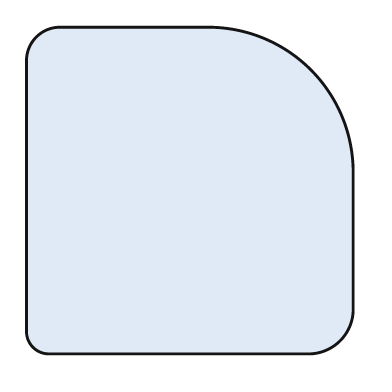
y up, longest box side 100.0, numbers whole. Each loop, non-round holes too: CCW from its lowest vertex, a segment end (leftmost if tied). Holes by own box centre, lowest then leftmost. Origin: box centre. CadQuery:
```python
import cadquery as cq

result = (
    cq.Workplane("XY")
    .moveTo(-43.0, -50.0)
    .lineTo(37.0, -50.0)
    .threePointArc((46.0, -46.0), (50.0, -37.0))
    .lineTo(50.0, 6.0)
    .threePointArc((37.0, 37.0), (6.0, 50.0))
    .lineTo(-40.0, 50.0)
    .threePointArc((-47.0, 47.0), (-50.0, 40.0))
    .lineTo(-50.0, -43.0)
    .threePointArc((-48.0, -48.0), (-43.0, -50.0))
    .close()
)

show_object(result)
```